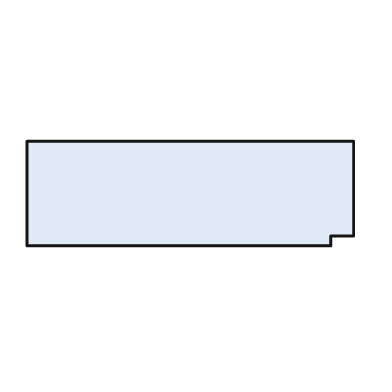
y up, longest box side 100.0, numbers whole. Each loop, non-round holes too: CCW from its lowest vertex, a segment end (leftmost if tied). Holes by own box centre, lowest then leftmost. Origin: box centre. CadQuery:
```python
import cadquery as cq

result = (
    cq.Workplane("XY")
    .moveTo(-50.0, -16.0)
    .lineTo(43.0, -16.0)
    .lineTo(43.0, -13.0)
    .lineTo(50.0, -13.0)
    .lineTo(50.0, 16.0)
    .lineTo(-50.0, 16.0)
    .close()
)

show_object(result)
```